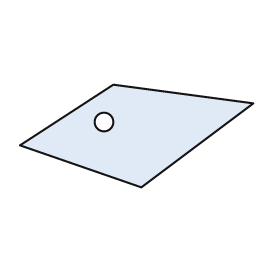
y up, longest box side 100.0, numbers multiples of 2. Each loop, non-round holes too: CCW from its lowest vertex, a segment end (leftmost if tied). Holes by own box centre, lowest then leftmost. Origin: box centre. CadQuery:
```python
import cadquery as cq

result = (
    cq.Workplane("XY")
    .moveTo(2.0, -22.0)
    .lineTo(50.0, 14.0)
    .lineTo(-10.0, 22.0)
    .lineTo(-50.0, -4.0)
    .close()
    .moveTo(-14.0, 6.0)
    .circle(4.0)
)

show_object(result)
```